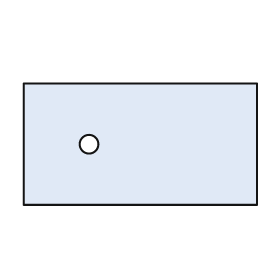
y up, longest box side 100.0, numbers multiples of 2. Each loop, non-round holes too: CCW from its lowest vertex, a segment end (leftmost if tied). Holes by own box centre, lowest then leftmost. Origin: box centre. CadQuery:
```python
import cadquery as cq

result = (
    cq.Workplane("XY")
    .moveTo(-50.0, -26.0)
    .lineTo(50.0, -26.0)
    .lineTo(50.0, 26.0)
    .lineTo(-50.0, 26.0)
    .close()
    .moveTo(-22.0, 0.0)
    .circle(4.0)
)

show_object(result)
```